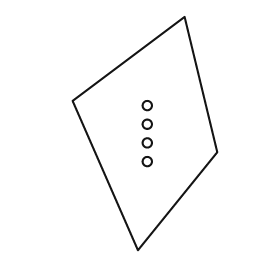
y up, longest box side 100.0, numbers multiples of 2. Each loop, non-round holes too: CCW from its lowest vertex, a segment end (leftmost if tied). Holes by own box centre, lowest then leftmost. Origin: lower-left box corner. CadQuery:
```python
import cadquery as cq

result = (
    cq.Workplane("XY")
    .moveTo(28.0, 0.0)
    .lineTo(62.0, 42.0)
    .lineTo(48.0, 100.0)
    .lineTo(0.0, 64.0)
    .close()
    .moveTo(32.0, 38.0)
    .circle(2.0)
    .moveTo(32.0, 46.0)
    .circle(2.0)
    .moveTo(32.0, 54.0)
    .circle(2.0)
    .moveTo(32.0, 62.0)
    .circle(2.0)
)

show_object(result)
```